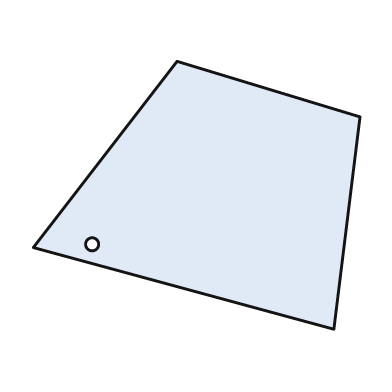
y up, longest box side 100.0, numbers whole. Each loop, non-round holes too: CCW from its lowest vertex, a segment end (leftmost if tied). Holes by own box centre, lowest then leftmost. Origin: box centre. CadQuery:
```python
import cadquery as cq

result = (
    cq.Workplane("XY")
    .moveTo(42.0, -41.0)
    .lineTo(50.0, 24.0)
    .lineTo(-6.0, 41.0)
    .lineTo(-50.0, -16.0)
    .close()
    .moveTo(-32.0, -15.0)
    .circle(2.0)
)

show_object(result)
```